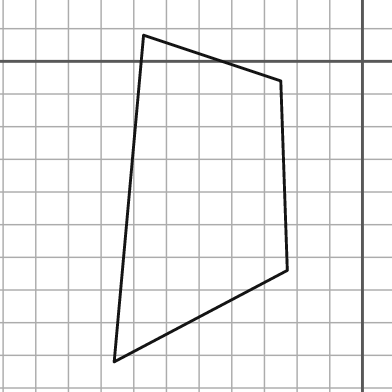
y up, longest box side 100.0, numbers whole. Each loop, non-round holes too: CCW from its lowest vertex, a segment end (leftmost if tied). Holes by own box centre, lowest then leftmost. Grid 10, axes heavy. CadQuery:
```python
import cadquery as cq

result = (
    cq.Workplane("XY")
    .moveTo(-76.0, -92.0)
    .lineTo(-23.0, -64.0)
    .lineTo(-25.0, -6.0)
    .lineTo(-67.0, 8.0)
    .close()
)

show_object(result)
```